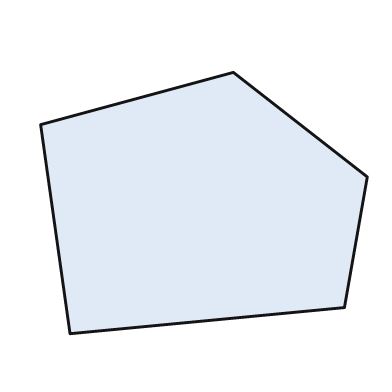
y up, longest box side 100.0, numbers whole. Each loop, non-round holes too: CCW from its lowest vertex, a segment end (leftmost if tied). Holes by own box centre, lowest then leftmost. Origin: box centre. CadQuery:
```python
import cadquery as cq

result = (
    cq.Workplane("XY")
    .moveTo(-41.0, -40.0)
    .lineTo(43.0, -32.0)
    .lineTo(50.0, 8.0)
    .lineTo(9.0, 40.0)
    .lineTo(-50.0, 24.0)
    .close()
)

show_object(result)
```